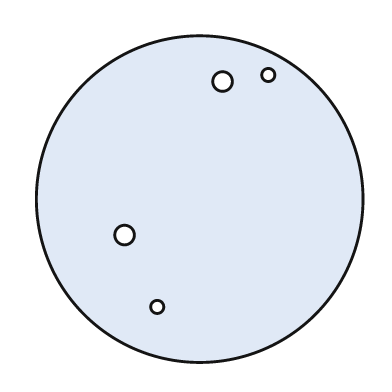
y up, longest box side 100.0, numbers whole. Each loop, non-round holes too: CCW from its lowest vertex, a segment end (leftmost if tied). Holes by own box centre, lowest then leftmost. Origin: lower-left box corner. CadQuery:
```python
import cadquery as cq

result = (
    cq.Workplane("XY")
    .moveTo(50.0, 50.0)
    .circle(50.0)
    .moveTo(37.0, 17.0)
    .circle(2.0)
    .moveTo(27.0, 39.0)
    .circle(3.0)
    .moveTo(57.0, 86.0)
    .circle(3.0)
    .moveTo(71.0, 88.0)
    .circle(2.0)
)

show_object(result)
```